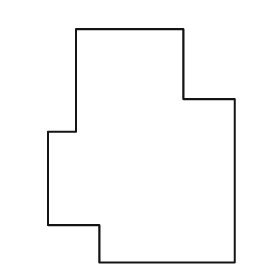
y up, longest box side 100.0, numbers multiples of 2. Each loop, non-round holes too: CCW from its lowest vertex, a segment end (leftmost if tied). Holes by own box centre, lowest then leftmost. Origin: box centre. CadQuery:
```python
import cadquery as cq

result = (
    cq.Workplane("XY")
    .moveTo(-18.0, -50.0)
    .lineTo(40.0, -50.0)
    .lineTo(40.0, 20.0)
    .lineTo(18.0, 20.0)
    .lineTo(18.0, 50.0)
    .lineTo(-28.0, 50.0)
    .lineTo(-28.0, 6.0)
    .lineTo(-40.0, 6.0)
    .lineTo(-40.0, -34.0)
    .lineTo(-18.0, -34.0)
    .close()
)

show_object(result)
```